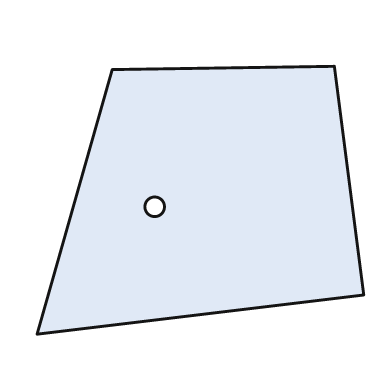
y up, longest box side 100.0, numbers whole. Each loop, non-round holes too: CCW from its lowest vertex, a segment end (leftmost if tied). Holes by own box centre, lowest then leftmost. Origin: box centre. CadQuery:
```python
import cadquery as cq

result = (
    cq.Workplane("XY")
    .moveTo(-50.0, -41.0)
    .lineTo(50.0, -29.0)
    .lineTo(41.0, 41.0)
    .lineTo(-27.0, 40.0)
    .close()
    .moveTo(-14.0, -2.0)
    .circle(3.0)
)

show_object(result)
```